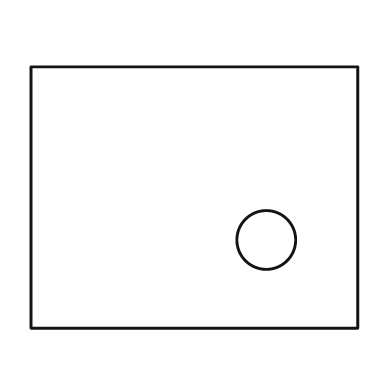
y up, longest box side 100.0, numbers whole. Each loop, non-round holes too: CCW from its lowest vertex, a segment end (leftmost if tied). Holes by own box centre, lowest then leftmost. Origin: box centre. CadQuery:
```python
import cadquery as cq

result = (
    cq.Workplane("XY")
    .moveTo(-50.0, -40.0)
    .lineTo(50.0, -40.0)
    .lineTo(50.0, 40.0)
    .lineTo(-50.0, 40.0)
    .close()
    .moveTo(22.0, -13.0)
    .circle(9.0)
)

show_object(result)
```